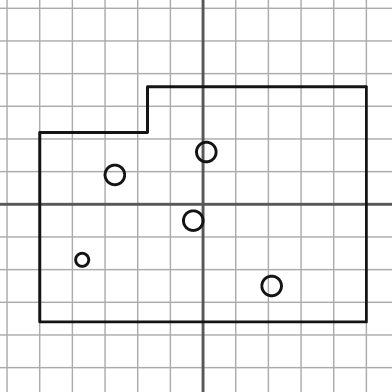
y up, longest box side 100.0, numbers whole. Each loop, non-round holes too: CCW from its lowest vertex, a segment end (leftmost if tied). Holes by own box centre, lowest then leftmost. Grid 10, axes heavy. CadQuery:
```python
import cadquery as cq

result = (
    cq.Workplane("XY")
    .moveTo(-50.0, -36.0)
    .lineTo(50.0, -36.0)
    .lineTo(50.0, 36.0)
    .lineTo(-17.0, 36.0)
    .lineTo(-17.0, 22.0)
    .lineTo(-50.0, 22.0)
    .close()
    .moveTo(21.0, -25.0)
    .circle(3.0)
    .moveTo(-37.0, -17.0)
    .circle(2.0)
    .moveTo(-3.0, -5.0)
    .circle(3.0)
    .moveTo(-27.0, 9.0)
    .circle(3.0)
    .moveTo(1.0, 16.0)
    .circle(3.0)
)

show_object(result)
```